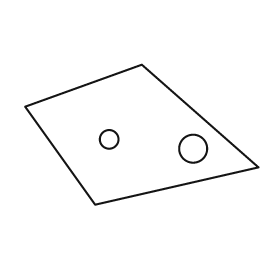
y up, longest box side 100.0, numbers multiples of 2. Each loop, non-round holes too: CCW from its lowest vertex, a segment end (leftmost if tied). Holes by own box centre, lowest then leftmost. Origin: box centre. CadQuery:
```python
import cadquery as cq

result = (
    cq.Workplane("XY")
    .moveTo(-20.0, -30.0)
    .lineTo(50.0, -14.0)
    .lineTo(0.0, 30.0)
    .lineTo(-50.0, 12.0)
    .close()
    .moveTo(22.0, -6.0)
    .circle(6.0)
    .moveTo(-14.0, -2.0)
    .circle(4.0)
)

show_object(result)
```